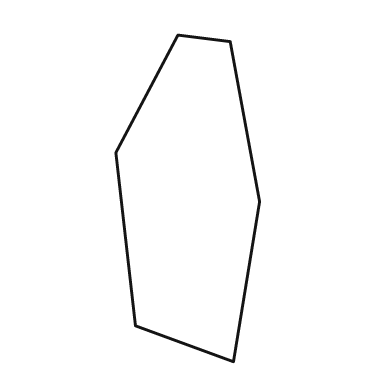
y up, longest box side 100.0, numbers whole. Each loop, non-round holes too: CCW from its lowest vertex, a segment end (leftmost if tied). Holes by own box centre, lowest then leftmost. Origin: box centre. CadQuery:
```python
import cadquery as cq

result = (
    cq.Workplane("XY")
    .moveTo(14.0, -50.0)
    .lineTo(22.0, -1.0)
    .lineTo(13.0, 48.0)
    .lineTo(-3.0, 50.0)
    .lineTo(-22.0, 14.0)
    .lineTo(-16.0, -39.0)
    .close()
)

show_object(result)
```